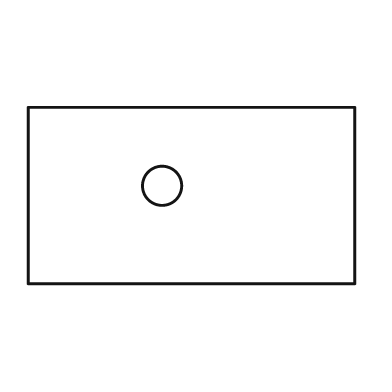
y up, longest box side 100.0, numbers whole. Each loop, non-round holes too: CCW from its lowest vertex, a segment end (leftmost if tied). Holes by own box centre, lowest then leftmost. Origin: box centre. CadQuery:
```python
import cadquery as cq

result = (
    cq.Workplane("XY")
    .moveTo(-50.0, -27.0)
    .lineTo(50.0, -27.0)
    .lineTo(50.0, 27.0)
    .lineTo(-50.0, 27.0)
    .close()
    .moveTo(-9.0, 3.0)
    .circle(6.0)
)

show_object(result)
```